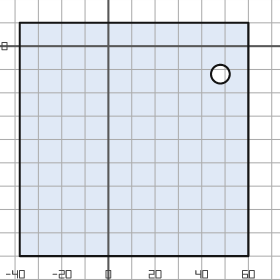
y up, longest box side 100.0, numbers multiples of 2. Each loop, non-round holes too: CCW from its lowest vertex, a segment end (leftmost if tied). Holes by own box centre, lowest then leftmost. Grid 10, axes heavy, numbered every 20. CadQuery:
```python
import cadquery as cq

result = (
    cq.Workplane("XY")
    .moveTo(-38.0, -90.0)
    .lineTo(60.0, -90.0)
    .lineTo(60.0, 10.0)
    .lineTo(-38.0, 10.0)
    .close()
    .moveTo(48.0, -12.0)
    .circle(4.0)
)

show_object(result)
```